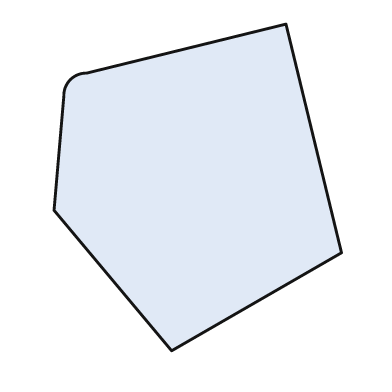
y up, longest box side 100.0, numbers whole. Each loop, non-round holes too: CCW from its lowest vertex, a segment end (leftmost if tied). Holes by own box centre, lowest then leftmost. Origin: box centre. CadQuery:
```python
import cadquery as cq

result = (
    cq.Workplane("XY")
    .moveTo(-8.0, -50.0)
    .lineTo(44.0, -20.0)
    .lineTo(27.0, 50.0)
    .lineTo(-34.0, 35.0)
    .threePointArc((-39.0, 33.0), (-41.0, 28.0))
    .lineTo(-44.0, -7.0)
    .close()
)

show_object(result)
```